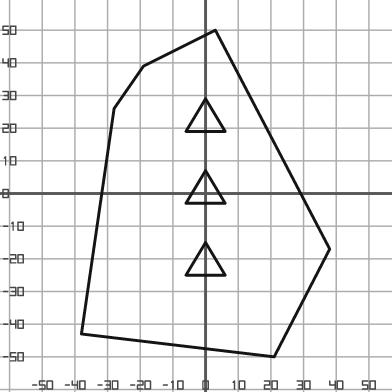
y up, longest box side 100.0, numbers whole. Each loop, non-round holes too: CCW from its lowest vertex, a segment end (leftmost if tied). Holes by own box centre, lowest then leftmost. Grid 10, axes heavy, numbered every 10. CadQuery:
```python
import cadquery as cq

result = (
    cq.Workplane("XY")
    .moveTo(21.0, -50.0)
    .lineTo(38.0, -17.0)
    .lineTo(3.0, 50.0)
    .lineTo(-19.0, 39.0)
    .lineTo(-28.0, 26.0)
    .lineTo(-38.0, -43.0)
    .close()
    .moveTo(-6.0, -25.0)
    .lineTo(6.0, -25.0)
    .lineTo(0.0, -15.0)
    .close()
    .moveTo(-6.0, -3.0)
    .lineTo(6.0, -3.0)
    .lineTo(0.0, 7.0)
    .close()
    .moveTo(-6.0, 19.0)
    .lineTo(6.0, 19.0)
    .lineTo(0.0, 29.0)
    .close()
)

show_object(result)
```